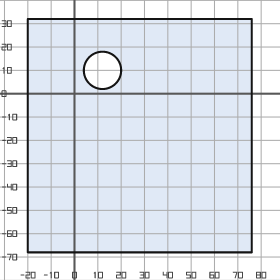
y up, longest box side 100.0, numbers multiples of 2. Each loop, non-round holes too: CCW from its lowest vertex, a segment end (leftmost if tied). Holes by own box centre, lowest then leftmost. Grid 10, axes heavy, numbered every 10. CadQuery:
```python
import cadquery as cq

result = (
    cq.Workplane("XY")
    .moveTo(-20.0, -68.0)
    .lineTo(76.0, -68.0)
    .lineTo(76.0, 32.0)
    .lineTo(-20.0, 32.0)
    .close()
    .moveTo(12.0, 10.0)
    .circle(8.0)
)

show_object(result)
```